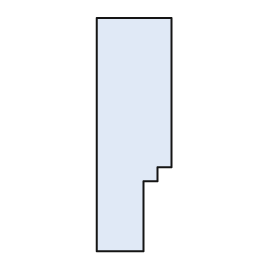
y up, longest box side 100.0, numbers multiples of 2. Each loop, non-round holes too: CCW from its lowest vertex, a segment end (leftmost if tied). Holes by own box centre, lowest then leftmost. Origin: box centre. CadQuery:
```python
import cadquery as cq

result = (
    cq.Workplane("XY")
    .moveTo(-16.0, -50.0)
    .lineTo(4.0, -50.0)
    .lineTo(4.0, -20.0)
    .lineTo(10.0, -20.0)
    .lineTo(10.0, -14.0)
    .lineTo(16.0, -14.0)
    .lineTo(16.0, 50.0)
    .lineTo(-16.0, 50.0)
    .close()
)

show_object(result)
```